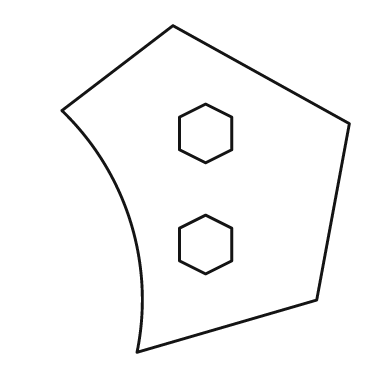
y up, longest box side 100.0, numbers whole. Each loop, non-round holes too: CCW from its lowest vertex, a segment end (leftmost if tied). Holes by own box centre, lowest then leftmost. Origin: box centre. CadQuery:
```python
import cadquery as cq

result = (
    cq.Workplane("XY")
    .moveTo(-21.0, -50.0)
    .lineTo(34.0, -34.0)
    .lineTo(44.0, 20.0)
    .lineTo(-10.0, 50.0)
    .lineTo(-44.0, 24.0)
    .threePointArc((-23.0, -10.0), (-21.0, -50.0))
    .close()
    .moveTo(0.0, -26.0)
    .lineTo(8.0, -22.0)
    .lineTo(8.0, -12.0)
    .lineTo(0.0, -8.0)
    .lineTo(-8.0, -12.0)
    .lineTo(-8.0, -22.0)
    .close()
    .moveTo(0.0, 8.0)
    .lineTo(8.0, 12.0)
    .lineTo(8.0, 22.0)
    .lineTo(0.0, 26.0)
    .lineTo(-8.0, 22.0)
    .lineTo(-8.0, 12.0)
    .close()
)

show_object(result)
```